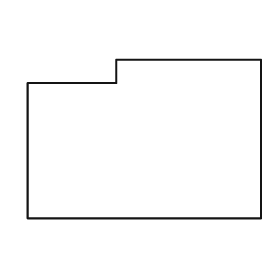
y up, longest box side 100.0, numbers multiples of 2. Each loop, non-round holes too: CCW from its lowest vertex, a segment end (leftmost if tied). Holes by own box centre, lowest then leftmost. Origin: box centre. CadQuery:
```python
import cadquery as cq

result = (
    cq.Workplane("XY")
    .moveTo(-50.0, -34.0)
    .lineTo(50.0, -34.0)
    .lineTo(50.0, 34.0)
    .lineTo(-12.0, 34.0)
    .lineTo(-12.0, 24.0)
    .lineTo(-50.0, 24.0)
    .close()
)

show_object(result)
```